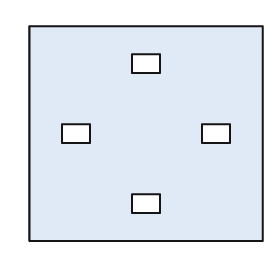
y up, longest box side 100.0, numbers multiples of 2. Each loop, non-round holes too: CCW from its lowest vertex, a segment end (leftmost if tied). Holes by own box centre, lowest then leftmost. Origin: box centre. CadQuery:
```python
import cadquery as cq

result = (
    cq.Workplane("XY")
    .moveTo(-50.0, -46.0)
    .lineTo(50.0, -46.0)
    .lineTo(50.0, 46.0)
    .lineTo(-50.0, 46.0)
    .close()
    .moveTo(-6.0, -34.0)
    .lineTo(6.0, -34.0)
    .lineTo(6.0, -26.0)
    .lineTo(-6.0, -26.0)
    .close()
    .moveTo(-36.0, -4.0)
    .lineTo(-24.0, -4.0)
    .lineTo(-24.0, 4.0)
    .lineTo(-36.0, 4.0)
    .close()
    .moveTo(24.0, -4.0)
    .lineTo(36.0, -4.0)
    .lineTo(36.0, 4.0)
    .lineTo(24.0, 4.0)
    .close()
    .moveTo(-6.0, 26.0)
    .lineTo(6.0, 26.0)
    .lineTo(6.0, 34.0)
    .lineTo(-6.0, 34.0)
    .close()
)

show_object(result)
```